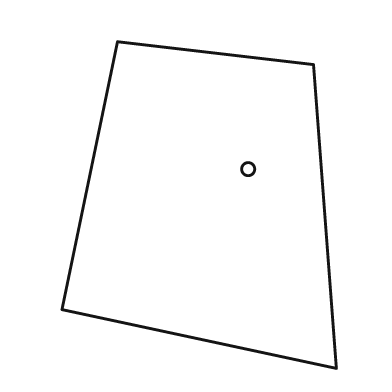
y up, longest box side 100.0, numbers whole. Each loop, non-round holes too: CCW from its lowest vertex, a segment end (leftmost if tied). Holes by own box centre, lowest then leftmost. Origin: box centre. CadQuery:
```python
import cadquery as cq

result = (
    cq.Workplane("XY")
    .moveTo(42.0, -50.0)
    .lineTo(35.0, 43.0)
    .lineTo(-25.0, 50.0)
    .lineTo(-42.0, -32.0)
    .close()
    .moveTo(15.0, 11.0)
    .circle(2.0)
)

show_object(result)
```